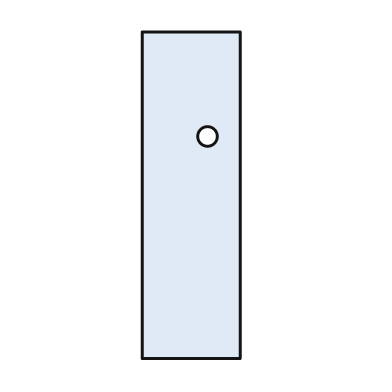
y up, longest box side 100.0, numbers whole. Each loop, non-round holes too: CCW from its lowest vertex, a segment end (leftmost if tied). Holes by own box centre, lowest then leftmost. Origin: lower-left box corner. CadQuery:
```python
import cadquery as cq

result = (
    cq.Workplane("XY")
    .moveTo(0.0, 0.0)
    .lineTo(30.0, 0.0)
    .lineTo(30.0, 100.0)
    .lineTo(0.0, 100.0)
    .close()
    .moveTo(20.0, 68.0)
    .circle(3.0)
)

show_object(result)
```